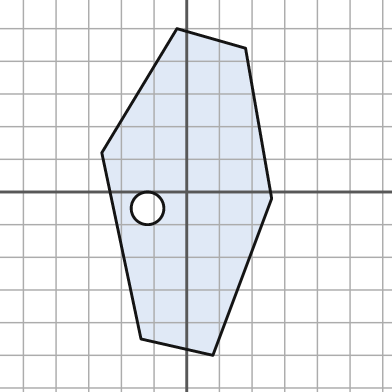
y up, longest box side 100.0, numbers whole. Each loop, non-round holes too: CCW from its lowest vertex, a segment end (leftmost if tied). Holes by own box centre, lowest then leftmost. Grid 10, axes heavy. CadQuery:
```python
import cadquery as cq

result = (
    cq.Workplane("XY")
    .moveTo(8.0, -50.0)
    .lineTo(26.0, -2.0)
    .lineTo(18.0, 44.0)
    .lineTo(-3.0, 50.0)
    .lineTo(-26.0, 12.0)
    .lineTo(-14.0, -45.0)
    .close()
    .moveTo(-12.0, -5.0)
    .circle(5.0)
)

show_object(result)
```